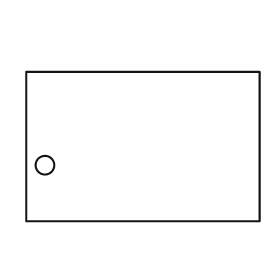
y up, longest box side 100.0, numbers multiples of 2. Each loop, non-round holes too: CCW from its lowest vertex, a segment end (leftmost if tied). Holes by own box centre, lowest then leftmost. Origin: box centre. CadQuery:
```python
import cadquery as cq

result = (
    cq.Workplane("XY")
    .moveTo(-50.0, -32.0)
    .lineTo(50.0, -32.0)
    .lineTo(50.0, 32.0)
    .lineTo(-50.0, 32.0)
    .close()
    .moveTo(-42.0, -8.0)
    .circle(4.0)
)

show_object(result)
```